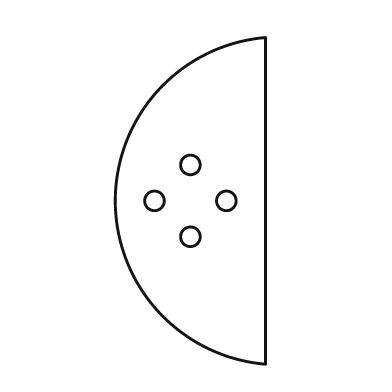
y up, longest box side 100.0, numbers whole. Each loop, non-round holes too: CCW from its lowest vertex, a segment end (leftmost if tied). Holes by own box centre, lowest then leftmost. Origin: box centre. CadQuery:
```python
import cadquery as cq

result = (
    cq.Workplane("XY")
    .moveTo(23.0, -50.0)
    .lineTo(23.0, 50.0)
    .threePointArc((-23.0, 0.0), (23.0, -50.0))
    .close()
    .moveTo(0.0, -11.0)
    .circle(3.0)
    .moveTo(-11.0, 0.0)
    .circle(3.0)
    .moveTo(11.0, 0.0)
    .circle(3.0)
    .moveTo(0.0, 11.0)
    .circle(3.0)
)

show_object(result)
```